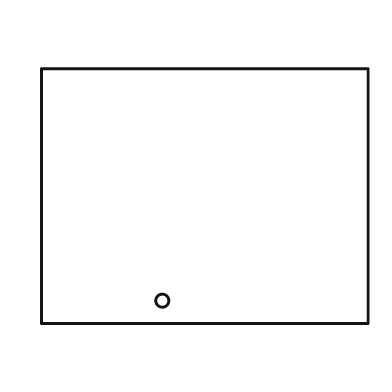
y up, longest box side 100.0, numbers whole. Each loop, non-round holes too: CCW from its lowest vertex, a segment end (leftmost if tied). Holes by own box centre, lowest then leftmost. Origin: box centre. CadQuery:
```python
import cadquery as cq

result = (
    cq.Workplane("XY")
    .moveTo(-50.0, -39.0)
    .lineTo(50.0, -39.0)
    .lineTo(50.0, 39.0)
    .lineTo(-50.0, 39.0)
    .close()
    .moveTo(-13.0, -32.0)
    .circle(2.0)
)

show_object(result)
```